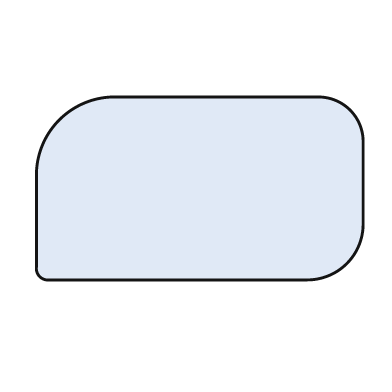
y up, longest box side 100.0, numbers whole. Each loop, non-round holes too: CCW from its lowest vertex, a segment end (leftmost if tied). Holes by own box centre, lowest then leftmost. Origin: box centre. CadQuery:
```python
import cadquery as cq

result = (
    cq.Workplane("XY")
    .moveTo(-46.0, -28.0)
    .lineTo(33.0, -28.0)
    .threePointArc((45.0, -23.0), (50.0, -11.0))
    .lineTo(50.0, 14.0)
    .threePointArc((46.0, 24.0), (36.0, 28.0))
    .lineTo(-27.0, 28.0)
    .threePointArc((-43.0, 21.0), (-50.0, 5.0))
    .lineTo(-50.0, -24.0)
    .threePointArc((-49.0, -27.0), (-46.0, -28.0))
    .close()
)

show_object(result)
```